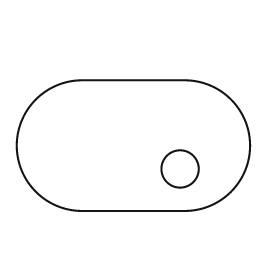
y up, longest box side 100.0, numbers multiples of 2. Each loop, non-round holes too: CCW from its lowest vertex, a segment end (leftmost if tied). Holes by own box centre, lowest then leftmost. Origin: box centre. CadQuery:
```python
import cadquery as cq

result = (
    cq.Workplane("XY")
    .moveTo(-22.0, -28.0)
    .lineTo(22.0, -28.0)
    .threePointArc((50.0, 0.0), (22.0, 28.0))
    .lineTo(-22.0, 28.0)
    .threePointArc((-50.0, 0.0), (-22.0, -28.0))
    .close()
    .moveTo(20.0, -10.0)
    .circle(8.0)
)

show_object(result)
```